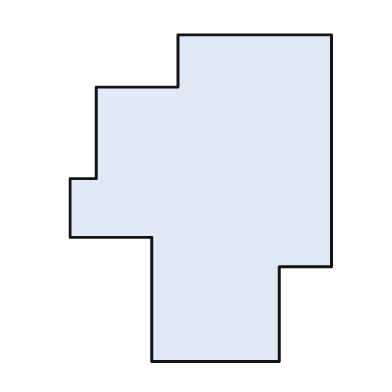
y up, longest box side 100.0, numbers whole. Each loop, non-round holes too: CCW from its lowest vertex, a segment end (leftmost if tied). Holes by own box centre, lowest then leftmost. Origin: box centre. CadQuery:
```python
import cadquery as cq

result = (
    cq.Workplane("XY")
    .moveTo(-15.0, -50.0)
    .lineTo(24.0, -50.0)
    .lineTo(24.0, -21.0)
    .lineTo(40.0, -21.0)
    .lineTo(40.0, 50.0)
    .lineTo(-7.0, 50.0)
    .lineTo(-7.0, 34.0)
    .lineTo(-32.0, 34.0)
    .lineTo(-32.0, 6.0)
    .lineTo(-40.0, 6.0)
    .lineTo(-40.0, -12.0)
    .lineTo(-15.0, -12.0)
    .close()
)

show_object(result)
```